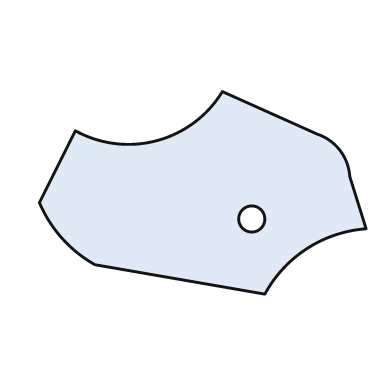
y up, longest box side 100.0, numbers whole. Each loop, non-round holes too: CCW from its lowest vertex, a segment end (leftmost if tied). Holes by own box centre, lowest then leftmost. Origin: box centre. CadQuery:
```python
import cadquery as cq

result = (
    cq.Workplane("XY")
    .moveTo(19.0, -31.0)
    .threePointArc((32.0, -17.0), (50.0, -11.0))
    .lineTo(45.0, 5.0)
    .threePointArc((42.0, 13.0), (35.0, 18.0))
    .lineTo(6.0, 31.0)
    .threePointArc((-14.0, 16.0), (-39.0, 19.0))
    .lineTo(-50.0, -3.0)
    .threePointArc((-43.0, -14.0), (-33.0, -22.0))
    .close()
    .moveTo(15.0, -8.0)
    .circle(4.0)
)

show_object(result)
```